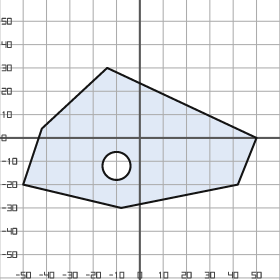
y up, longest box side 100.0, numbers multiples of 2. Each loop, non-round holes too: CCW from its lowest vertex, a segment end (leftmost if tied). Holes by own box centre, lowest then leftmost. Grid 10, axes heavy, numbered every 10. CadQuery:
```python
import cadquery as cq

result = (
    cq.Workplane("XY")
    .moveTo(-8.0, -30.0)
    .lineTo(42.0, -20.0)
    .lineTo(50.0, 0.0)
    .lineTo(-14.0, 30.0)
    .lineTo(-42.0, 4.0)
    .lineTo(-50.0, -20.0)
    .close()
    .moveTo(-10.0, -12.0)
    .circle(6.0)
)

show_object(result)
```